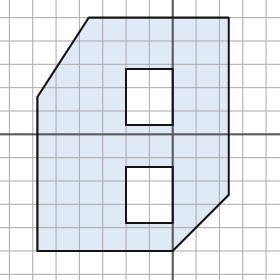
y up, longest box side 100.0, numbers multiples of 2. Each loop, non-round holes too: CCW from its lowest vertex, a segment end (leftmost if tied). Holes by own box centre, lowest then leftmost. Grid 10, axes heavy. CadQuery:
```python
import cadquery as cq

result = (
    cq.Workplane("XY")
    .moveTo(-58.0, -50.0)
    .lineTo(0.0, -50.0)
    .lineTo(24.0, -26.0)
    .lineTo(24.0, 50.0)
    .lineTo(-36.0, 50.0)
    .lineTo(-58.0, 16.0)
    .close()
    .moveTo(-20.0, -38.0)
    .lineTo(0.0, -38.0)
    .lineTo(0.0, -14.0)
    .lineTo(-20.0, -14.0)
    .close()
    .moveTo(-20.0, 4.0)
    .lineTo(0.0, 4.0)
    .lineTo(0.0, 28.0)
    .lineTo(-20.0, 28.0)
    .close()
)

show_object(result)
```